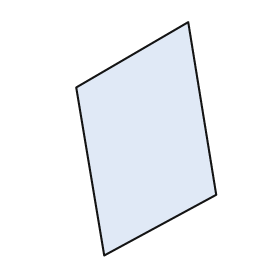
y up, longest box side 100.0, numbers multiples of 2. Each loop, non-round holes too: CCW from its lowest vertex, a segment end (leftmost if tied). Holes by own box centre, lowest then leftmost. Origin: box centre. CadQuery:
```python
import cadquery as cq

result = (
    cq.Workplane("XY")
    .moveTo(-18.0, -50.0)
    .lineTo(30.0, -24.0)
    .lineTo(18.0, 50.0)
    .lineTo(-30.0, 22.0)
    .close()
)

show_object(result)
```